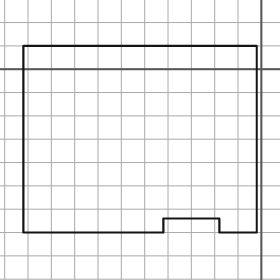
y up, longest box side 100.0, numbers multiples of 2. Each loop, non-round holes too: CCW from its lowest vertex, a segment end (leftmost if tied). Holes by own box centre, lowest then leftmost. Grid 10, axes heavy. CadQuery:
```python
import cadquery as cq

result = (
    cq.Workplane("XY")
    .moveTo(-102.0, -70.0)
    .lineTo(-42.0, -70.0)
    .lineTo(-42.0, -64.0)
    .lineTo(-18.0, -64.0)
    .lineTo(-18.0, -70.0)
    .lineTo(-2.0, -70.0)
    .lineTo(-2.0, 10.0)
    .lineTo(-102.0, 10.0)
    .close()
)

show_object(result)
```